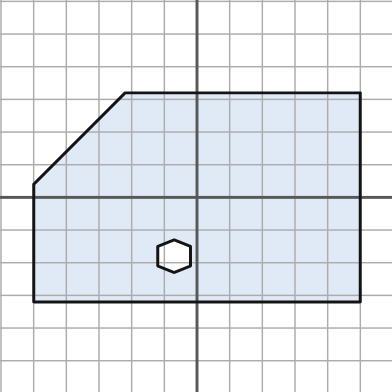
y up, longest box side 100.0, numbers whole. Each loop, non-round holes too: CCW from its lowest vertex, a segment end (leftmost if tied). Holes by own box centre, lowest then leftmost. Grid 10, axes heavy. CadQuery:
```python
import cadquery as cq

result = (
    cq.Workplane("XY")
    .moveTo(-50.0, -32.0)
    .lineTo(50.0, -32.0)
    .lineTo(50.0, 32.0)
    .lineTo(-22.0, 32.0)
    .lineTo(-50.0, 4.0)
    .close()
    .moveTo(-7.0, -23.0)
    .lineTo(-2.0, -21.0)
    .lineTo(-2.0, -15.0)
    .lineTo(-7.0, -13.0)
    .lineTo(-12.0, -15.0)
    .lineTo(-12.0, -21.0)
    .close()
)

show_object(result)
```